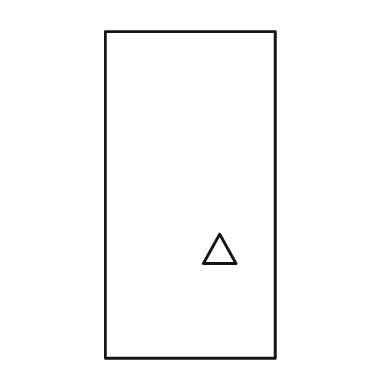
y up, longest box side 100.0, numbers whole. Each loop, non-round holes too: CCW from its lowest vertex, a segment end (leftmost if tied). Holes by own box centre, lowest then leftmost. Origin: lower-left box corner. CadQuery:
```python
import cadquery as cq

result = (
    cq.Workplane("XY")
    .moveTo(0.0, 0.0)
    .lineTo(52.0, 0.0)
    .lineTo(52.0, 100.0)
    .lineTo(0.0, 100.0)
    .close()
    .moveTo(30.0, 29.0)
    .lineTo(40.0, 29.0)
    .lineTo(35.0, 38.0)
    .close()
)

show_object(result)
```